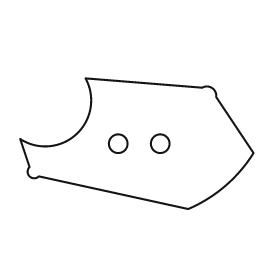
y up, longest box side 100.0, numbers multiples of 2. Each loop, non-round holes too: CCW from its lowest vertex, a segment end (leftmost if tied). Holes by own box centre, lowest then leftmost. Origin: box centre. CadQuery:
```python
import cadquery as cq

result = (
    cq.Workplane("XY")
    .moveTo(22.0, -28.0)
    .threePointArc((38.0, -18.0), (50.0, -4.0))
    .lineTo(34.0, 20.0)
    .threePointArc((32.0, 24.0), (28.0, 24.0))
    .lineTo(-22.0, 28.0)
    .threePointArc((-26.0, 4.0), (-50.0, 2.0))
    .lineTo(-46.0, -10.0)
    .threePointArc((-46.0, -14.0), (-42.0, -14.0))
    .close()
    .moveTo(-8.0, 0.0)
    .circle(4.0)
    .moveTo(10.0, 0.0)
    .circle(4.0)
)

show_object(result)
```